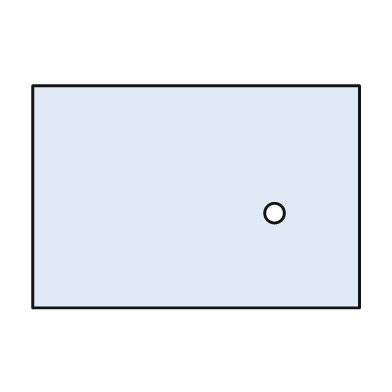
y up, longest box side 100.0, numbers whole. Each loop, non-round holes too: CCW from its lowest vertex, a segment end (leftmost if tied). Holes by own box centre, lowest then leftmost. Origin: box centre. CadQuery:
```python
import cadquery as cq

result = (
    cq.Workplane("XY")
    .moveTo(-50.0, -34.0)
    .lineTo(50.0, -34.0)
    .lineTo(50.0, 34.0)
    .lineTo(-50.0, 34.0)
    .close()
    .moveTo(24.0, -5.0)
    .circle(3.0)
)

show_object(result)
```